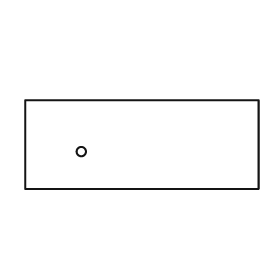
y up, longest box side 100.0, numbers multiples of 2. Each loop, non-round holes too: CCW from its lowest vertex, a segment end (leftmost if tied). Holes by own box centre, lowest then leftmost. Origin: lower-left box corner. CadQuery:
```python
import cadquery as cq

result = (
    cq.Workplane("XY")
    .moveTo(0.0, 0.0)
    .lineTo(100.0, 0.0)
    .lineTo(100.0, 38.0)
    .lineTo(0.0, 38.0)
    .close()
    .moveTo(24.0, 16.0)
    .circle(2.0)
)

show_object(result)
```